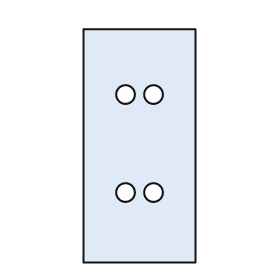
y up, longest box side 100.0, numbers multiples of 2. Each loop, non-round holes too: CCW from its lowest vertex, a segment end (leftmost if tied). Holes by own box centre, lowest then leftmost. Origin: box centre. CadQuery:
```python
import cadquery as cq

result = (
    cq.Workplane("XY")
    .moveTo(-24.0, -50.0)
    .lineTo(24.0, -50.0)
    .lineTo(24.0, 50.0)
    .lineTo(-24.0, 50.0)
    .close()
    .moveTo(-6.0, -20.0)
    .circle(4.0)
    .moveTo(6.0, -20.0)
    .circle(4.0)
    .moveTo(-6.0, 22.0)
    .circle(4.0)
    .moveTo(6.0, 22.0)
    .circle(4.0)
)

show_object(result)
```